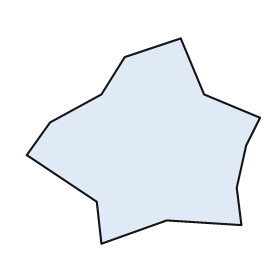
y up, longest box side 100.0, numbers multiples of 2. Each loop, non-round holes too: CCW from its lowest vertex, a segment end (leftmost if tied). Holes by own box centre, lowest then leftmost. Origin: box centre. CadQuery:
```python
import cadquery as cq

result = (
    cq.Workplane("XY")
    .moveTo(-18.0, -44.0)
    .lineTo(10.0, -34.0)
    .lineTo(42.0, -36.0)
    .lineTo(40.0, -20.0)
    .lineTo(44.0, -2.0)
    .lineTo(50.0, 10.0)
    .lineTo(26.0, 20.0)
    .lineTo(16.0, 44.0)
    .lineTo(-8.0, 36.0)
    .lineTo(-18.0, 20.0)
    .lineTo(-40.0, 8.0)
    .lineTo(-50.0, -6.0)
    .lineTo(-20.0, -26.0)
    .close()
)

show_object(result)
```